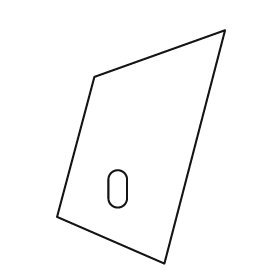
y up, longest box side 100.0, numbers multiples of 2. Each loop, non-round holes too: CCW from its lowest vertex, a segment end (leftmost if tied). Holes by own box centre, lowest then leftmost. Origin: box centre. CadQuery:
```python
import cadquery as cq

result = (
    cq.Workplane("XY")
    .moveTo(10.0, -50.0)
    .lineTo(36.0, 50.0)
    .lineTo(-20.0, 30.0)
    .lineTo(-36.0, -30.0)
    .close()
    .moveTo(-14.0, -22.0)
    .threePointArc((-10.0, -26.0), (-6.0, -22.0))
    .lineTo(-6.0, -14.0)
    .threePointArc((-10.0, -10.0), (-14.0, -14.0))
    .close()
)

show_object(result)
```